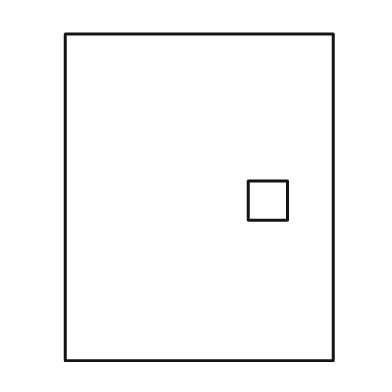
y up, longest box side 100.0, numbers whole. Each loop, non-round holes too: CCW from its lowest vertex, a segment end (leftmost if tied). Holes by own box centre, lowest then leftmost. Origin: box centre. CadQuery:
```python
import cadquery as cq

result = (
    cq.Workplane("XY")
    .moveTo(-41.0, -50.0)
    .lineTo(41.0, -50.0)
    .lineTo(41.0, 50.0)
    .lineTo(-41.0, 50.0)
    .close()
    .moveTo(15.0, -7.0)
    .lineTo(27.0, -7.0)
    .lineTo(27.0, 5.0)
    .lineTo(15.0, 5.0)
    .close()
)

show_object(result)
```